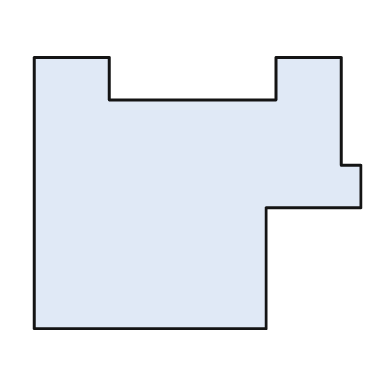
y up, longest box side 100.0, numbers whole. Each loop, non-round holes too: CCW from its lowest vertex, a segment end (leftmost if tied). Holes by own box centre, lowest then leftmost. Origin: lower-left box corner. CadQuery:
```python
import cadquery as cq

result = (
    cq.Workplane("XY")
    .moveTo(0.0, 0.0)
    .lineTo(71.0, 0.0)
    .lineTo(71.0, 37.0)
    .lineTo(100.0, 37.0)
    .lineTo(100.0, 50.0)
    .lineTo(94.0, 50.0)
    .lineTo(94.0, 83.0)
    .lineTo(74.0, 83.0)
    .lineTo(74.0, 70.0)
    .lineTo(23.0, 70.0)
    .lineTo(23.0, 83.0)
    .lineTo(0.0, 83.0)
    .close()
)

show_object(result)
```